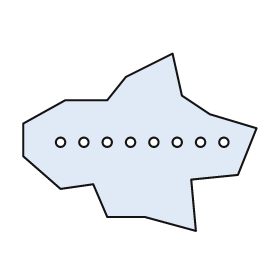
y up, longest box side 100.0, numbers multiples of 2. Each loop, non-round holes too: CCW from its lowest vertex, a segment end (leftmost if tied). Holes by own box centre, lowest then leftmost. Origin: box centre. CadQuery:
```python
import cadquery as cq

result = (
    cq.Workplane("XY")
    .moveTo(24.0, -38.0)
    .lineTo(22.0, -16.0)
    .lineTo(42.0, -14.0)
    .lineTo(50.0, 6.0)
    .lineTo(30.0, 12.0)
    .lineTo(18.0, 20.0)
    .lineTo(14.0, 38.0)
    .lineTo(-6.0, 28.0)
    .lineTo(-14.0, 18.0)
    .lineTo(-32.0, 18.0)
    .lineTo(-50.0, 8.0)
    .lineTo(-50.0, -6.0)
    .lineTo(-34.0, -20.0)
    .lineTo(-20.0, -18.0)
    .lineTo(-14.0, -32.0)
    .lineTo(2.0, -32.0)
    .close()
    .moveTo(-34.0, 0.0)
    .circle(2.0)
    .moveTo(-24.0, 0.0)
    .circle(2.0)
    .moveTo(-14.0, 0.0)
    .circle(2.0)
    .moveTo(-4.0, 0.0)
    .circle(2.0)
    .moveTo(6.0, 0.0)
    .circle(2.0)
    .moveTo(16.0, 0.0)
    .circle(2.0)
    .moveTo(26.0, 0.0)
    .circle(2.0)
    .moveTo(36.0, 0.0)
    .circle(2.0)
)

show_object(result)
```